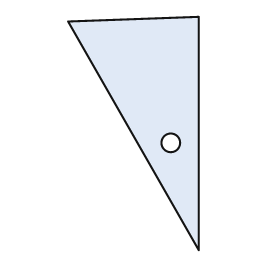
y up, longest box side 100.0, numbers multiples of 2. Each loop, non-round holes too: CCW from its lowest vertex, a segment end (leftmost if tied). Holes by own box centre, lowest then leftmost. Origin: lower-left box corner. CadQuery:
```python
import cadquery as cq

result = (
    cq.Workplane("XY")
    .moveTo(56.0, 0.0)
    .lineTo(56.0, 100.0)
    .lineTo(0.0, 98.0)
    .close()
    .moveTo(44.0, 46.0)
    .circle(4.0)
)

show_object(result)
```